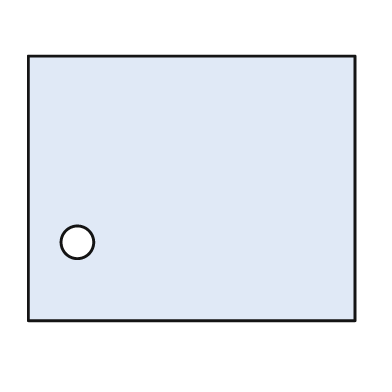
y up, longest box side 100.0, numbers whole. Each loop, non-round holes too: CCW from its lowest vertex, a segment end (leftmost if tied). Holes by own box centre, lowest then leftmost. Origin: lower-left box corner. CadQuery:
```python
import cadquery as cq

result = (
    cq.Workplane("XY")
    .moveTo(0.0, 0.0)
    .lineTo(100.0, 0.0)
    .lineTo(100.0, 81.0)
    .lineTo(0.0, 81.0)
    .close()
    .moveTo(15.0, 24.0)
    .circle(5.0)
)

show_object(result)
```